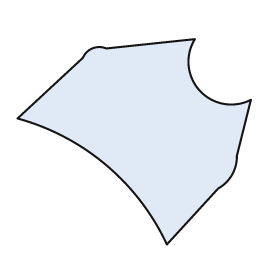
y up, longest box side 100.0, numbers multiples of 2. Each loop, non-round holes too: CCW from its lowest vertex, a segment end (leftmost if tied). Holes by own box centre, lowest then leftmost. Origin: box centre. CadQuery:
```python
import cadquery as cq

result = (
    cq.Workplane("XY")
    .moveTo(14.0, -44.0)
    .lineTo(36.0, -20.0)
    .threePointArc((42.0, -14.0), (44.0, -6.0))
    .lineTo(50.0, 18.0)
    .threePointArc((28.0, 22.0), (26.0, 44.0))
    .lineTo(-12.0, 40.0)
    .threePointArc((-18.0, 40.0), (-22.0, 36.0))
    .lineTo(-50.0, 10.0)
    .threePointArc((-12.0, -10.0), (14.0, -44.0))
    .close()
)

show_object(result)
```